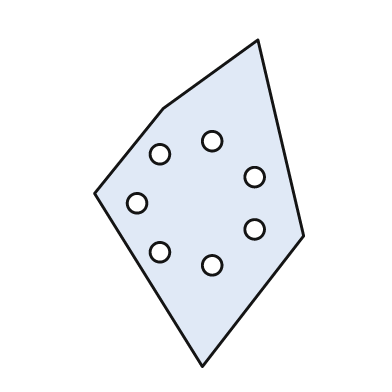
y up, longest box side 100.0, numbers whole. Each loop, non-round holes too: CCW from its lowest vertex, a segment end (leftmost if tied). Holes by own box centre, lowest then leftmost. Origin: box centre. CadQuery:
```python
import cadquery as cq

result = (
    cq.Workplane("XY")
    .moveTo(1.0, -50.0)
    .lineTo(32.0, -10.0)
    .lineTo(18.0, 50.0)
    .lineTo(-11.0, 29.0)
    .lineTo(-32.0, 3.0)
    .close()
    .moveTo(4.0, -19.0)
    .circle(3.0)
    .moveTo(-12.0, -15.0)
    .circle(3.0)
    .moveTo(17.0, -8.0)
    .circle(3.0)
    .moveTo(-19.0, 0.0)
    .circle(3.0)
    .moveTo(17.0, 8.0)
    .circle(3.0)
    .moveTo(-12.0, 15.0)
    .circle(3.0)
    .moveTo(4.0, 19.0)
    .circle(3.0)
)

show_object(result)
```